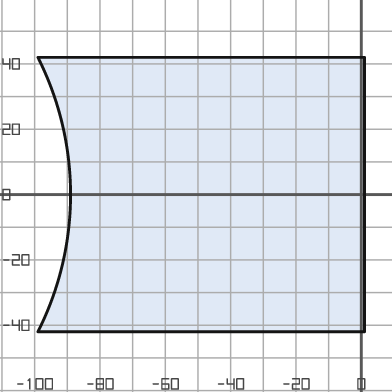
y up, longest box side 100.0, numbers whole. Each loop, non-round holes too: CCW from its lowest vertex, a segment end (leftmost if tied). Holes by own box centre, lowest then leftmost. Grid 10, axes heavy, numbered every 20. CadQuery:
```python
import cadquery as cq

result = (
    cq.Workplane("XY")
    .moveTo(-99.0, -42.0)
    .lineTo(1.0, -42.0)
    .lineTo(1.0, 42.0)
    .lineTo(-99.0, 42.0)
    .threePointArc((-89.0, 0.0), (-99.0, -42.0))
    .close()
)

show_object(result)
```